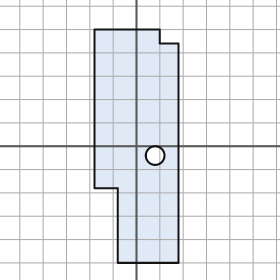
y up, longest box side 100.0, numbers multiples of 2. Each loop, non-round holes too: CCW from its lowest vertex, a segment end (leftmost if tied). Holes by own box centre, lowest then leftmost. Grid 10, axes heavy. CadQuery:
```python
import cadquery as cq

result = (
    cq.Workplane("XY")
    .moveTo(-8.0, -50.0)
    .lineTo(18.0, -50.0)
    .lineTo(18.0, 44.0)
    .lineTo(10.0, 44.0)
    .lineTo(10.0, 50.0)
    .lineTo(-18.0, 50.0)
    .lineTo(-18.0, -18.0)
    .lineTo(-8.0, -18.0)
    .close()
    .moveTo(8.0, -4.0)
    .circle(4.0)
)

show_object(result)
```